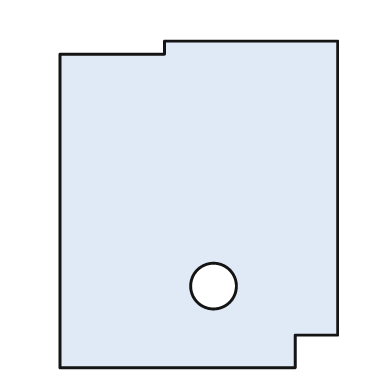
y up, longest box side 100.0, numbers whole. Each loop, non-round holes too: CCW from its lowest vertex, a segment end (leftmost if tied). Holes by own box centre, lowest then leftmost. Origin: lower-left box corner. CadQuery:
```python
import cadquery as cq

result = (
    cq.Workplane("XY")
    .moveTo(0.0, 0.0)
    .lineTo(72.0, 0.0)
    .lineTo(72.0, 10.0)
    .lineTo(85.0, 10.0)
    .lineTo(85.0, 100.0)
    .lineTo(32.0, 100.0)
    .lineTo(32.0, 96.0)
    .lineTo(0.0, 96.0)
    .close()
    .moveTo(47.0, 25.0)
    .circle(7.0)
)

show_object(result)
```